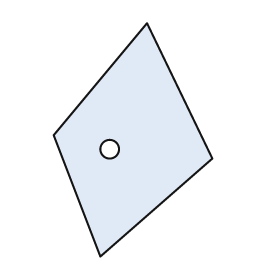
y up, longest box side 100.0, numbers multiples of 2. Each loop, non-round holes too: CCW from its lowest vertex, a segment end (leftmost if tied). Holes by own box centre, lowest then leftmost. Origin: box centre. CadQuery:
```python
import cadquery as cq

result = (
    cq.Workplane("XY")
    .moveTo(-14.0, -50.0)
    .lineTo(34.0, -8.0)
    .lineTo(6.0, 50.0)
    .lineTo(-34.0, 2.0)
    .close()
    .moveTo(-10.0, -4.0)
    .circle(4.0)
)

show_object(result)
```